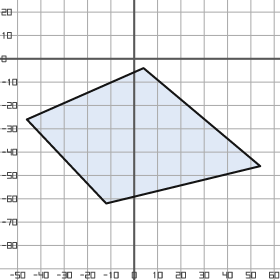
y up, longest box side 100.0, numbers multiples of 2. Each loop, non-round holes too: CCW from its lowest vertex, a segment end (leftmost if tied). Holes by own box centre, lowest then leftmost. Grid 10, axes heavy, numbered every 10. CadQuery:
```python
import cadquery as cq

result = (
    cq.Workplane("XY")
    .moveTo(-12.0, -62.0)
    .lineTo(54.0, -46.0)
    .lineTo(4.0, -4.0)
    .lineTo(-46.0, -26.0)
    .close()
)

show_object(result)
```